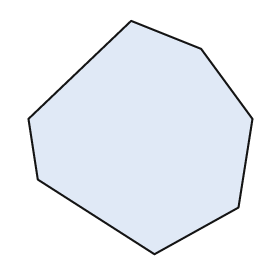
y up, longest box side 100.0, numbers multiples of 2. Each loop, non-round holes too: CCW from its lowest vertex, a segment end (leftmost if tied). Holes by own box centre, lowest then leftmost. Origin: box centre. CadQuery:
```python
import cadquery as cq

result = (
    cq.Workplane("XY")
    .moveTo(6.0, -50.0)
    .lineTo(42.0, -30.0)
    .lineTo(48.0, 8.0)
    .lineTo(26.0, 38.0)
    .lineTo(-4.0, 50.0)
    .lineTo(-48.0, 8.0)
    .lineTo(-44.0, -18.0)
    .close()
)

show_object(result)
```